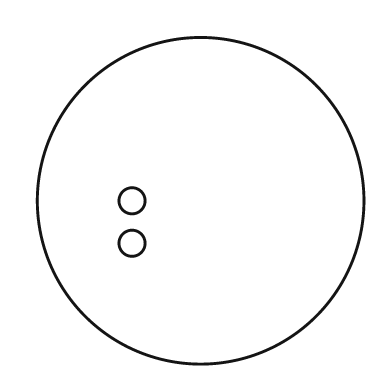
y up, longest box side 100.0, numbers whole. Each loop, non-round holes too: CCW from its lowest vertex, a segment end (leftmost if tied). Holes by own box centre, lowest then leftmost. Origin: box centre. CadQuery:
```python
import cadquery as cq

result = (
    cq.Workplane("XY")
    .moveTo(0.0, 0.0)
    .circle(50.0)
    .moveTo(-21.0, -13.0)
    .circle(4.0)
    .moveTo(-21.0, 0.0)
    .circle(4.0)
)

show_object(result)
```